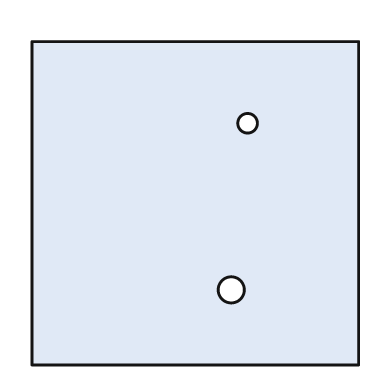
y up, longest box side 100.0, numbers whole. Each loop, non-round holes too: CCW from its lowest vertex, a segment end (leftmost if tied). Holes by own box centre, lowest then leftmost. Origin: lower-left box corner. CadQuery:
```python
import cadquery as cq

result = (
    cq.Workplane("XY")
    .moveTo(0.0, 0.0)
    .lineTo(100.0, 0.0)
    .lineTo(100.0, 99.0)
    .lineTo(0.0, 99.0)
    .close()
    .moveTo(61.0, 23.0)
    .circle(4.0)
    .moveTo(66.0, 74.0)
    .circle(3.0)
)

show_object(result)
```